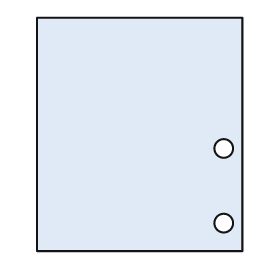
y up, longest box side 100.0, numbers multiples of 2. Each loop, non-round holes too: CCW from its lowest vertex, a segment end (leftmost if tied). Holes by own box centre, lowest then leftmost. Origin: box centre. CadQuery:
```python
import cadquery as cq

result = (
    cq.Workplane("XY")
    .moveTo(-44.0, -50.0)
    .lineTo(44.0, -50.0)
    .lineTo(44.0, 50.0)
    .lineTo(-44.0, 50.0)
    .close()
    .moveTo(36.0, -38.0)
    .circle(4.0)
    .moveTo(36.0, -6.0)
    .circle(4.0)
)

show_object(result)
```